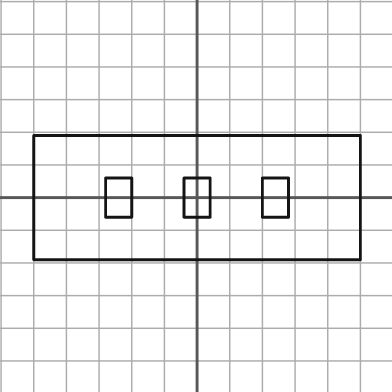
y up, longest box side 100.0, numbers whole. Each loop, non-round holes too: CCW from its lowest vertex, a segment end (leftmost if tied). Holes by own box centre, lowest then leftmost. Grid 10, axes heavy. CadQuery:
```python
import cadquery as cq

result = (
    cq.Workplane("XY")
    .moveTo(-50.0, -19.0)
    .lineTo(50.0, -19.0)
    .lineTo(50.0, 19.0)
    .lineTo(-50.0, 19.0)
    .close()
    .moveTo(-28.0, -6.0)
    .lineTo(-20.0, -6.0)
    .lineTo(-20.0, 6.0)
    .lineTo(-28.0, 6.0)
    .close()
    .moveTo(-4.0, -6.0)
    .lineTo(4.0, -6.0)
    .lineTo(4.0, 6.0)
    .lineTo(-4.0, 6.0)
    .close()
    .moveTo(20.0, -6.0)
    .lineTo(28.0, -6.0)
    .lineTo(28.0, 6.0)
    .lineTo(20.0, 6.0)
    .close()
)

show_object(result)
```